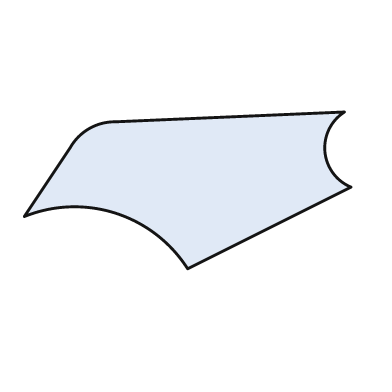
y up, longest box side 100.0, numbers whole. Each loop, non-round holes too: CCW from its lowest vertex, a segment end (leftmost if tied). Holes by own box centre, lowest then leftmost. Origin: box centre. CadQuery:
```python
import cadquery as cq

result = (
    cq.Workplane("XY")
    .moveTo(0.0, -24.0)
    .lineTo(50.0, 1.0)
    .threePointArc((42.0, 12.0), (48.0, 24.0))
    .lineTo(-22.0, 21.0)
    .threePointArc((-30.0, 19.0), (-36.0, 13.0))
    .lineTo(-50.0, -8.0)
    .threePointArc((-22.0, -7.0), (0.0, -24.0))
    .close()
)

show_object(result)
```